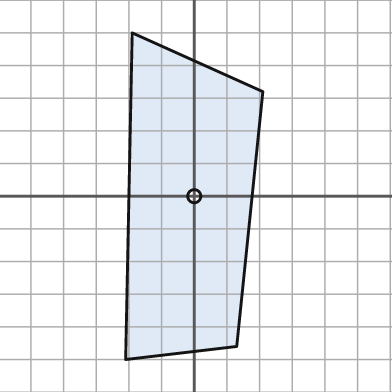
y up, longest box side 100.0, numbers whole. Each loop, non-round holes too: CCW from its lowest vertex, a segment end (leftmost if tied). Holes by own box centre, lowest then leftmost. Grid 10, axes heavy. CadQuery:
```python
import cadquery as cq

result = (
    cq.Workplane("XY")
    .moveTo(-21.0, -50.0)
    .lineTo(13.0, -46.0)
    .lineTo(21.0, 32.0)
    .lineTo(-19.0, 50.0)
    .close()
    .moveTo(0.0, 0.0)
    .circle(2.0)
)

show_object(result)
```